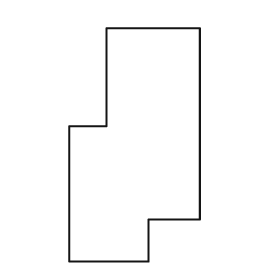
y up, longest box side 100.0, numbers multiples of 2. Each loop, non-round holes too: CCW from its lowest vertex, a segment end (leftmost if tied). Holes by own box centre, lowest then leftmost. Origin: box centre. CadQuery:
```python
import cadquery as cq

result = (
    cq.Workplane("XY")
    .moveTo(-28.0, -50.0)
    .lineTo(6.0, -50.0)
    .lineTo(6.0, -32.0)
    .lineTo(28.0, -32.0)
    .lineTo(28.0, 50.0)
    .lineTo(-12.0, 50.0)
    .lineTo(-12.0, 8.0)
    .lineTo(-28.0, 8.0)
    .close()
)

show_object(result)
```